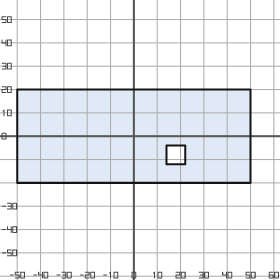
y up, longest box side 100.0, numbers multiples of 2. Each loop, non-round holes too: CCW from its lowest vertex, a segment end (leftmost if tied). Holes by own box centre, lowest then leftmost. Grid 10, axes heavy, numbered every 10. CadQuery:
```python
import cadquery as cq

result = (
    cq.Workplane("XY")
    .moveTo(-50.0, -20.0)
    .lineTo(50.0, -20.0)
    .lineTo(50.0, 20.0)
    .lineTo(-50.0, 20.0)
    .close()
    .moveTo(14.0, -12.0)
    .lineTo(22.0, -12.0)
    .lineTo(22.0, -4.0)
    .lineTo(14.0, -4.0)
    .close()
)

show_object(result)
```